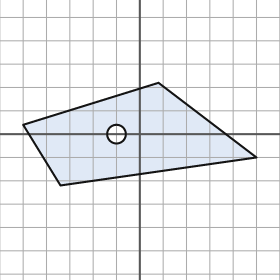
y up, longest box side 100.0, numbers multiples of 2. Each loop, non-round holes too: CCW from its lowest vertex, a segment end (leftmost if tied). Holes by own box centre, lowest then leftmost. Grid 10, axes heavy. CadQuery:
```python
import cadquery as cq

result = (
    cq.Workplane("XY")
    .moveTo(-34.0, -22.0)
    .lineTo(50.0, -10.0)
    .lineTo(8.0, 22.0)
    .lineTo(-50.0, 4.0)
    .close()
    .moveTo(-10.0, 0.0)
    .circle(4.0)
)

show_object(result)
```